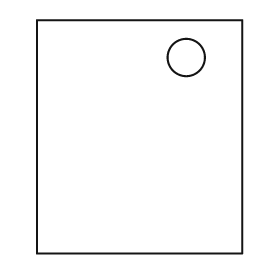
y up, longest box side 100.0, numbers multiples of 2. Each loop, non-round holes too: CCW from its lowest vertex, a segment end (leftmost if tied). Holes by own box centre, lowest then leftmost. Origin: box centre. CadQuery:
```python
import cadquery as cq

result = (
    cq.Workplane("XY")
    .moveTo(-44.0, -50.0)
    .lineTo(44.0, -50.0)
    .lineTo(44.0, 50.0)
    .lineTo(-44.0, 50.0)
    .close()
    .moveTo(20.0, 34.0)
    .circle(8.0)
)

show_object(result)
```